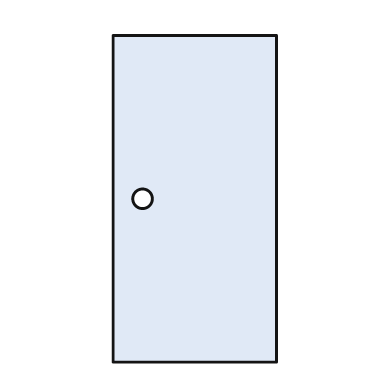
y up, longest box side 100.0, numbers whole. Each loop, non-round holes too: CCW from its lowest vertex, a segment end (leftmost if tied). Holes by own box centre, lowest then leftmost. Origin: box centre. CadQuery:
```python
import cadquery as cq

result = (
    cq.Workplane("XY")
    .moveTo(-25.0, -50.0)
    .lineTo(25.0, -50.0)
    .lineTo(25.0, 50.0)
    .lineTo(-25.0, 50.0)
    .close()
    .moveTo(-16.0, 0.0)
    .circle(3.0)
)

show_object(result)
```